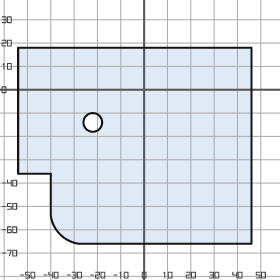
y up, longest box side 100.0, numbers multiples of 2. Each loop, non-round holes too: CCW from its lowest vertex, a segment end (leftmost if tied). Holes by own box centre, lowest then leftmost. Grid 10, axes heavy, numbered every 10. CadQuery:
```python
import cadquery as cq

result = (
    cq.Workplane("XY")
    .moveTo(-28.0, -66.0)
    .lineTo(46.0, -66.0)
    .lineTo(46.0, 18.0)
    .lineTo(-54.0, 18.0)
    .lineTo(-54.0, -36.0)
    .lineTo(-40.0, -36.0)
    .lineTo(-40.0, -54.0)
    .threePointArc((-36.0, -62.0), (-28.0, -66.0))
    .close()
    .moveTo(-22.0, -14.0)
    .circle(4.0)
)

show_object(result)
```